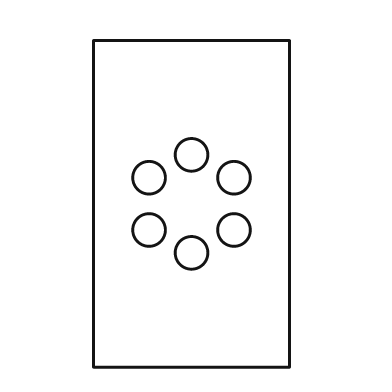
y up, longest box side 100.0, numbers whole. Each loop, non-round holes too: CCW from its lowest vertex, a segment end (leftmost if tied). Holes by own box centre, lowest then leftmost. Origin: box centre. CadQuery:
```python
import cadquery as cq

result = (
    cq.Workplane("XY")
    .moveTo(-30.0, -50.0)
    .lineTo(30.0, -50.0)
    .lineTo(30.0, 50.0)
    .lineTo(-30.0, 50.0)
    .close()
    .moveTo(0.0, -15.0)
    .circle(5.0)
    .moveTo(-13.0, -8.0)
    .circle(5.0)
    .moveTo(13.0, -8.0)
    .circle(5.0)
    .moveTo(-13.0, 8.0)
    .circle(5.0)
    .moveTo(13.0, 8.0)
    .circle(5.0)
    .moveTo(0.0, 15.0)
    .circle(5.0)
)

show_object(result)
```